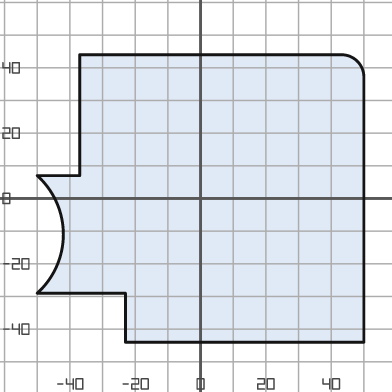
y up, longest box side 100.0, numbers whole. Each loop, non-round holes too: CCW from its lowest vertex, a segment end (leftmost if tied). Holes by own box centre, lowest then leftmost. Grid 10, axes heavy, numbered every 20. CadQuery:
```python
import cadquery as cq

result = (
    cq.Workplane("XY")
    .moveTo(-23.0, -44.0)
    .lineTo(50.0, -44.0)
    .lineTo(50.0, 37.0)
    .threePointArc((48.0, 42.0), (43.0, 44.0))
    .lineTo(-37.0, 44.0)
    .lineTo(-37.0, 7.0)
    .lineTo(-50.0, 7.0)
    .threePointArc((-42.0, -11.0), (-50.0, -29.0))
    .lineTo(-23.0, -29.0)
    .close()
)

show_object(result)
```